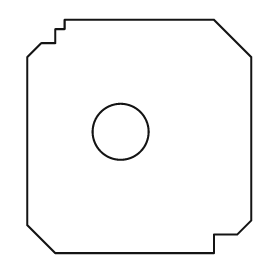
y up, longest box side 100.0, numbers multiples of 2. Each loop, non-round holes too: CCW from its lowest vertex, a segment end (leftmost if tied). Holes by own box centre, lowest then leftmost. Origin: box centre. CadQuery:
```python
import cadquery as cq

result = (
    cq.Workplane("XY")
    .moveTo(-36.0, -50.0)
    .lineTo(32.0, -50.0)
    .lineTo(32.0, -42.0)
    .lineTo(42.0, -42.0)
    .lineTo(48.0, -36.0)
    .lineTo(48.0, 34.0)
    .lineTo(32.0, 50.0)
    .lineTo(-32.0, 50.0)
    .lineTo(-32.0, 46.0)
    .lineTo(-36.0, 46.0)
    .lineTo(-36.0, 40.0)
    .lineTo(-42.0, 40.0)
    .lineTo(-48.0, 34.0)
    .lineTo(-48.0, -38.0)
    .close()
    .moveTo(-8.0, 2.0)
    .circle(12.0)
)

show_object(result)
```